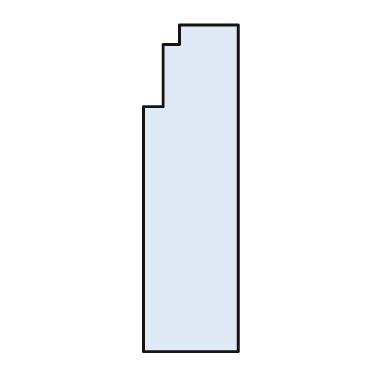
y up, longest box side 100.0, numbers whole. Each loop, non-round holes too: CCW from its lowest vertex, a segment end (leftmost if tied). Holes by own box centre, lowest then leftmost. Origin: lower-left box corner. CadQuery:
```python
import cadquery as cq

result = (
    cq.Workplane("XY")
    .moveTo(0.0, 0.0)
    .lineTo(29.0, 0.0)
    .lineTo(29.0, 100.0)
    .lineTo(11.0, 100.0)
    .lineTo(11.0, 94.0)
    .lineTo(6.0, 94.0)
    .lineTo(6.0, 75.0)
    .lineTo(0.0, 75.0)
    .close()
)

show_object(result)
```